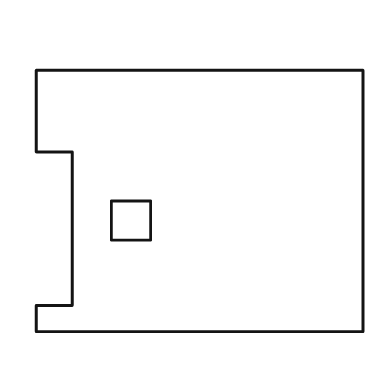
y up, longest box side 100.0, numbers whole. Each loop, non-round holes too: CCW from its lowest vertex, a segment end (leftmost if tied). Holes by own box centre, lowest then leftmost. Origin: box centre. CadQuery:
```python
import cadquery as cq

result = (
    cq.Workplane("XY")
    .moveTo(-50.0, -40.0)
    .lineTo(50.0, -40.0)
    .lineTo(50.0, 40.0)
    .lineTo(-50.0, 40.0)
    .lineTo(-50.0, 15.0)
    .lineTo(-39.0, 15.0)
    .lineTo(-39.0, -32.0)
    .lineTo(-50.0, -32.0)
    .close()
    .moveTo(-27.0, -12.0)
    .lineTo(-15.0, -12.0)
    .lineTo(-15.0, 0.0)
    .lineTo(-27.0, 0.0)
    .close()
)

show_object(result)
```